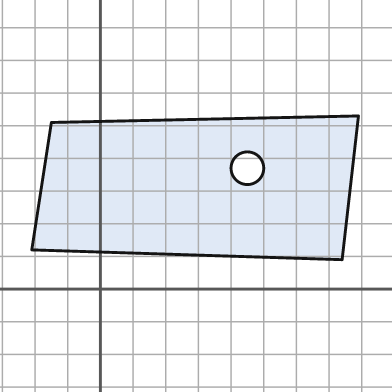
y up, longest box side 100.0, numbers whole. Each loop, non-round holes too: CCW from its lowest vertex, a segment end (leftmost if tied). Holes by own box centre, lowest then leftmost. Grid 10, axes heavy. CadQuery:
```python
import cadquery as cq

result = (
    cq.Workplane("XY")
    .moveTo(74.0, 9.0)
    .lineTo(79.0, 53.0)
    .lineTo(-15.0, 51.0)
    .lineTo(-21.0, 12.0)
    .close()
    .moveTo(45.0, 37.0)
    .circle(5.0)
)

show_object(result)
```